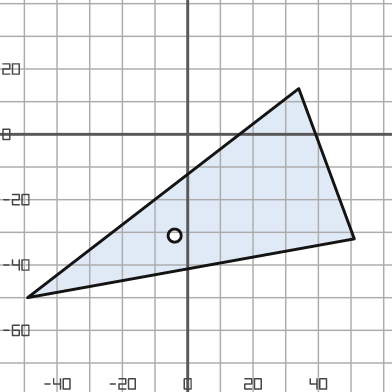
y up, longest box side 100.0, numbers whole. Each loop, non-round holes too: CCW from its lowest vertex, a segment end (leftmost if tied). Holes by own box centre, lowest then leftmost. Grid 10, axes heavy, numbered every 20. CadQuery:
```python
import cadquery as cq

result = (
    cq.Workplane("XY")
    .moveTo(-49.0, -50.0)
    .lineTo(51.0, -32.0)
    .lineTo(34.0, 14.0)
    .close()
    .moveTo(-4.0, -31.0)
    .circle(2.0)
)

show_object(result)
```